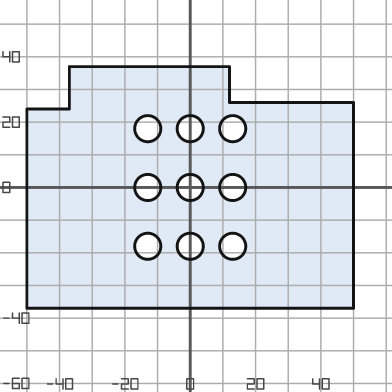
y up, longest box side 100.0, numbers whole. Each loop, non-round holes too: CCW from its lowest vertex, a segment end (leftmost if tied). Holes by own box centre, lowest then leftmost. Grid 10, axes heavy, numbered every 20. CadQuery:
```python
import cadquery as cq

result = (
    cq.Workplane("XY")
    .moveTo(-50.0, -37.0)
    .lineTo(50.0, -37.0)
    .lineTo(50.0, 26.0)
    .lineTo(12.0, 26.0)
    .lineTo(12.0, 37.0)
    .lineTo(-37.0, 37.0)
    .lineTo(-37.0, 24.0)
    .lineTo(-50.0, 24.0)
    .close()
    .moveTo(-13.0, -18.0)
    .circle(4.0)
    .moveTo(0.0, -18.0)
    .circle(4.0)
    .moveTo(13.0, -18.0)
    .circle(4.0)
    .moveTo(-13.0, 0.0)
    .circle(4.0)
    .moveTo(0.0, 0.0)
    .circle(4.0)
    .moveTo(13.0, 0.0)
    .circle(4.0)
    .moveTo(-13.0, 18.0)
    .circle(4.0)
    .moveTo(0.0, 18.0)
    .circle(4.0)
    .moveTo(13.0, 18.0)
    .circle(4.0)
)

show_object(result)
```